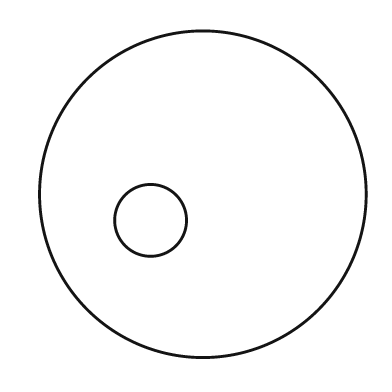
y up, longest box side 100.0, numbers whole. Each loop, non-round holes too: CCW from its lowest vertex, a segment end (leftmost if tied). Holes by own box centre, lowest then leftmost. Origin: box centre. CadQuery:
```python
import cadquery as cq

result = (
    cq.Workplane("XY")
    .moveTo(0.0, 0.0)
    .circle(50.0)
    .moveTo(-16.0, -8.0)
    .circle(11.0)
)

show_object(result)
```